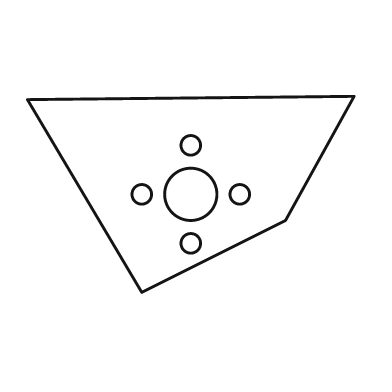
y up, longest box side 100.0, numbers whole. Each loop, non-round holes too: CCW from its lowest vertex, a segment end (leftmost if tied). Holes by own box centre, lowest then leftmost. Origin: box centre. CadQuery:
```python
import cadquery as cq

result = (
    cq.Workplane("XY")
    .moveTo(-15.0, -30.0)
    .lineTo(29.0, -8.0)
    .lineTo(50.0, 30.0)
    .lineTo(-50.0, 29.0)
    .close()
    .moveTo(0.0, -15.0)
    .circle(3.0)
    .moveTo(-15.0, 0.0)
    .circle(3.0)
    .moveTo(0.0, 0.0)
    .circle(8.0)
    .moveTo(15.0, 0.0)
    .circle(3.0)
    .moveTo(0.0, 15.0)
    .circle(3.0)
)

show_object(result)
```